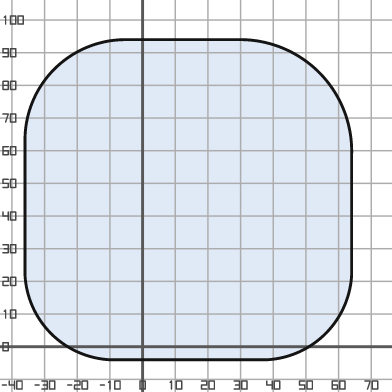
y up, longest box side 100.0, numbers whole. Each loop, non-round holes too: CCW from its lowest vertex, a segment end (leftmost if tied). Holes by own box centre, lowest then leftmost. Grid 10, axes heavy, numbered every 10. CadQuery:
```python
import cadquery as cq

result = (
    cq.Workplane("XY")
    .moveTo(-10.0, -4.0)
    .lineTo(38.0, -4.0)
    .threePointArc((56.0, 4.0), (64.0, 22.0))
    .lineTo(64.0, 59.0)
    .threePointArc((54.0, 84.0), (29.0, 94.0))
    .lineTo(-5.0, 94.0)
    .threePointArc((-27.0, 85.0), (-36.0, 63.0))
    .lineTo(-36.0, 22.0)
    .threePointArc((-28.0, 4.0), (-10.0, -4.0))
    .close()
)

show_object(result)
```